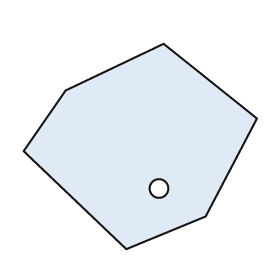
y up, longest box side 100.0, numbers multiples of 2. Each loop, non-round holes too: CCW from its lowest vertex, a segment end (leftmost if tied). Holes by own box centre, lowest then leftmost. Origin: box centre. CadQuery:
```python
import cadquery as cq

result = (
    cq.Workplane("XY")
    .moveTo(-6.0, -44.0)
    .lineTo(28.0, -30.0)
    .lineTo(50.0, 12.0)
    .lineTo(10.0, 44.0)
    .lineTo(-32.0, 24.0)
    .lineTo(-50.0, -2.0)
    .close()
    .moveTo(8.0, -18.0)
    .circle(4.0)
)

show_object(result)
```